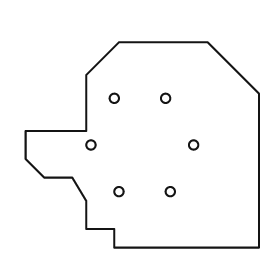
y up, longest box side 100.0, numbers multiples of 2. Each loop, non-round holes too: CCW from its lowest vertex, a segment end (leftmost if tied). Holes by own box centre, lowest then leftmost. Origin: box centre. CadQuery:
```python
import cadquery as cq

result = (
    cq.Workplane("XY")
    .moveTo(-12.0, -44.0)
    .lineTo(50.0, -44.0)
    .lineTo(50.0, 22.0)
    .lineTo(28.0, 44.0)
    .lineTo(-10.0, 44.0)
    .lineTo(-24.0, 30.0)
    .lineTo(-24.0, 6.0)
    .lineTo(-50.0, 6.0)
    .lineTo(-50.0, -6.0)
    .lineTo(-42.0, -14.0)
    .lineTo(-30.0, -14.0)
    .lineTo(-24.0, -24.0)
    .lineTo(-24.0, -36.0)
    .lineTo(-12.0, -36.0)
    .close()
    .moveTo(-10.0, -20.0)
    .circle(2.0)
    .moveTo(12.0, -20.0)
    .circle(2.0)
    .moveTo(-22.0, 0.0)
    .circle(2.0)
    .moveTo(22.0, 0.0)
    .circle(2.0)
    .moveTo(-12.0, 20.0)
    .circle(2.0)
    .moveTo(10.0, 20.0)
    .circle(2.0)
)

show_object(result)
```